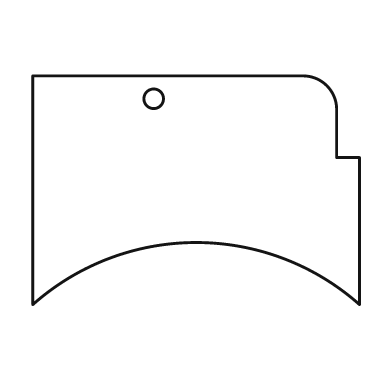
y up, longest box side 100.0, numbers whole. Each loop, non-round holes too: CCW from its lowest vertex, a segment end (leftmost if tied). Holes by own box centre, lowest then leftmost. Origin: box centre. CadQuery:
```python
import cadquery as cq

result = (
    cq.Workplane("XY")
    .moveTo(-50.0, -35.0)
    .threePointArc((0.0, -16.0), (50.0, -35.0))
    .lineTo(50.0, 10.0)
    .lineTo(43.0, 10.0)
    .lineTo(43.0, 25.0)
    .threePointArc((40.0, 32.0), (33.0, 35.0))
    .lineTo(-50.0, 35.0)
    .close()
    .moveTo(-13.0, 28.0)
    .circle(3.0)
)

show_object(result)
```